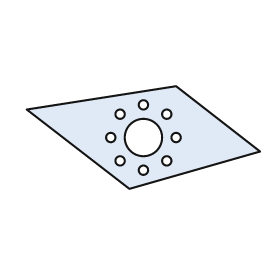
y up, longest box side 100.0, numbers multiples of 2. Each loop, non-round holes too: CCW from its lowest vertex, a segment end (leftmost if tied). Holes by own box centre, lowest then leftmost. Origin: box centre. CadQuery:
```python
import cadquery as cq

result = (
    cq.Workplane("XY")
    .moveTo(-6.0, -22.0)
    .lineTo(50.0, -6.0)
    .lineTo(14.0, 22.0)
    .lineTo(-50.0, 12.0)
    .close()
    .moveTo(0.0, -14.0)
    .circle(2.0)
    .moveTo(-10.0, -10.0)
    .circle(2.0)
    .moveTo(10.0, -10.0)
    .circle(2.0)
    .moveTo(-14.0, 0.0)
    .circle(2.0)
    .moveTo(0.0, 0.0)
    .circle(8.0)
    .moveTo(14.0, 0.0)
    .circle(2.0)
    .moveTo(-10.0, 10.0)
    .circle(2.0)
    .moveTo(10.0, 10.0)
    .circle(2.0)
    .moveTo(0.0, 14.0)
    .circle(2.0)
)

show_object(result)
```